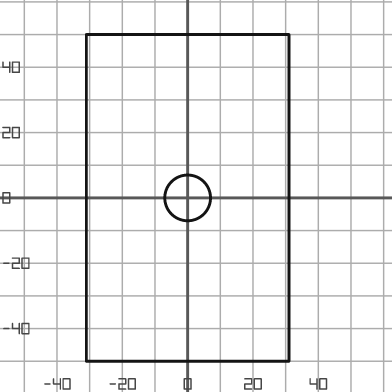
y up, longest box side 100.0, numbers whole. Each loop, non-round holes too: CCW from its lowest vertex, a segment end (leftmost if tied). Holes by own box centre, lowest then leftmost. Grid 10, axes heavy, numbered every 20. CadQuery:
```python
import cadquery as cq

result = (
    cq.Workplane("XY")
    .moveTo(-31.0, -50.0)
    .lineTo(31.0, -50.0)
    .lineTo(31.0, 50.0)
    .lineTo(-31.0, 50.0)
    .close()
    .moveTo(0.0, 0.0)
    .circle(7.0)
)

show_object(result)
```